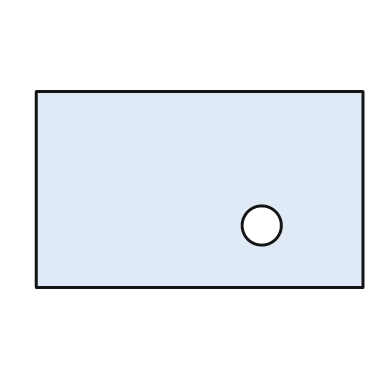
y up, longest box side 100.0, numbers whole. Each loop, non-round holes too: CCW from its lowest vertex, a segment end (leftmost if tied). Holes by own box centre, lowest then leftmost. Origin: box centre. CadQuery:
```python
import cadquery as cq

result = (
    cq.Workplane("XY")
    .moveTo(-50.0, -30.0)
    .lineTo(50.0, -30.0)
    .lineTo(50.0, 30.0)
    .lineTo(-50.0, 30.0)
    .close()
    .moveTo(19.0, -11.0)
    .circle(6.0)
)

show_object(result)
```